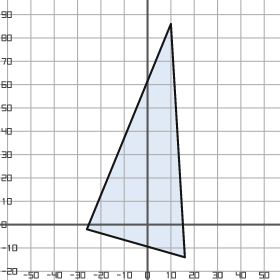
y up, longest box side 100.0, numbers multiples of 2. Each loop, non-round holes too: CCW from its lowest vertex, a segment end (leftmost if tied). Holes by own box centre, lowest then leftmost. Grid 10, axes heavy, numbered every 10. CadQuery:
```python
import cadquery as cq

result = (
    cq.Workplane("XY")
    .moveTo(16.0, -14.0)
    .lineTo(10.0, 86.0)
    .lineTo(-26.0, -2.0)
    .close()
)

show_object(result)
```